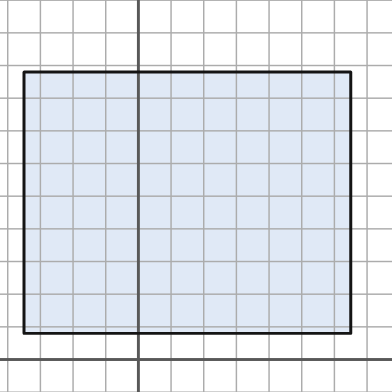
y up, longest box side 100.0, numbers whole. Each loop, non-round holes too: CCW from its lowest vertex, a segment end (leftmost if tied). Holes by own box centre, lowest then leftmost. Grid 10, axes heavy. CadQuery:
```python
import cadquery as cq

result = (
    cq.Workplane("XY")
    .moveTo(-35.0, 8.0)
    .lineTo(65.0, 8.0)
    .lineTo(65.0, 88.0)
    .lineTo(-35.0, 88.0)
    .close()
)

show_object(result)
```